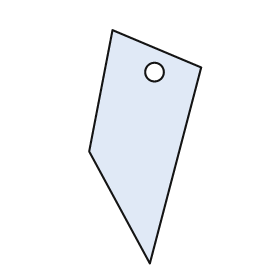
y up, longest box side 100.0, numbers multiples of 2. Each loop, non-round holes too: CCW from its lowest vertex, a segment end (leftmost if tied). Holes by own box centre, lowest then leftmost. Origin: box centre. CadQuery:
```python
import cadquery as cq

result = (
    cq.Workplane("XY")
    .moveTo(2.0, -50.0)
    .lineTo(24.0, 34.0)
    .lineTo(-14.0, 50.0)
    .lineTo(-24.0, -2.0)
    .close()
    .moveTo(4.0, 32.0)
    .circle(4.0)
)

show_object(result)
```